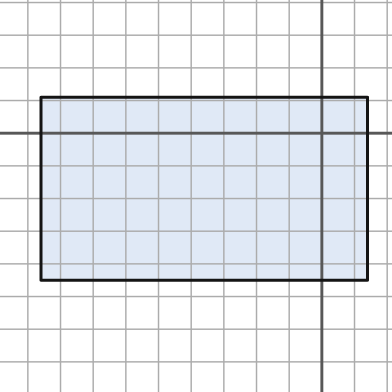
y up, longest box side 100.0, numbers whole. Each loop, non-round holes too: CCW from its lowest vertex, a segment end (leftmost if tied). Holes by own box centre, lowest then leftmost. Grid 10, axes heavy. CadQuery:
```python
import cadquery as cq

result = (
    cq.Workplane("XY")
    .moveTo(-86.0, -45.0)
    .lineTo(14.0, -45.0)
    .lineTo(14.0, 11.0)
    .lineTo(-86.0, 11.0)
    .close()
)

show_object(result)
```